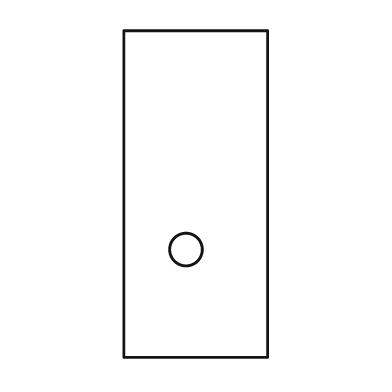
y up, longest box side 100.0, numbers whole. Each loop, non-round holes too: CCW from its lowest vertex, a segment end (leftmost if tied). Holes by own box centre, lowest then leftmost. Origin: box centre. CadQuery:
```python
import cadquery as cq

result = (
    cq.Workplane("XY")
    .moveTo(-22.0, -50.0)
    .lineTo(22.0, -50.0)
    .lineTo(22.0, 50.0)
    .lineTo(-22.0, 50.0)
    .close()
    .moveTo(-3.0, -17.0)
    .circle(5.0)
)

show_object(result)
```